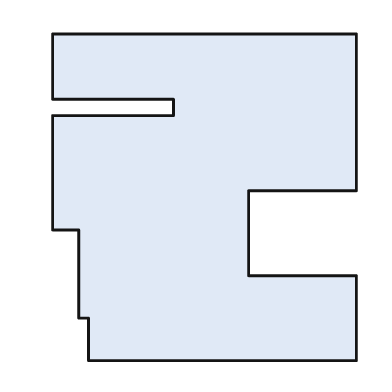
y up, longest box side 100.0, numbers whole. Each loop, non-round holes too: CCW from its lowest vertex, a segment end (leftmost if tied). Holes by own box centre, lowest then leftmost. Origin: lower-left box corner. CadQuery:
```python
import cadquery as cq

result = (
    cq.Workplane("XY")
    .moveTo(11.0, 0.0)
    .lineTo(93.0, 0.0)
    .lineTo(93.0, 26.0)
    .lineTo(60.0, 26.0)
    .lineTo(60.0, 52.0)
    .lineTo(93.0, 52.0)
    .lineTo(93.0, 100.0)
    .lineTo(0.0, 100.0)
    .lineTo(0.0, 80.0)
    .lineTo(37.0, 80.0)
    .lineTo(37.0, 75.0)
    .lineTo(0.0, 75.0)
    .lineTo(0.0, 40.0)
    .lineTo(8.0, 40.0)
    .lineTo(8.0, 13.0)
    .lineTo(11.0, 13.0)
    .close()
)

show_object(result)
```